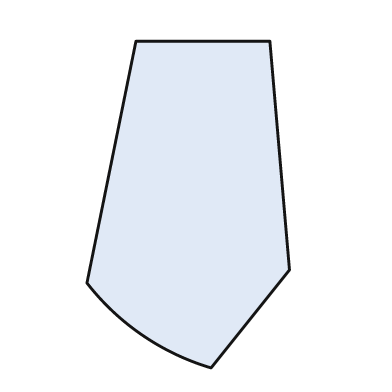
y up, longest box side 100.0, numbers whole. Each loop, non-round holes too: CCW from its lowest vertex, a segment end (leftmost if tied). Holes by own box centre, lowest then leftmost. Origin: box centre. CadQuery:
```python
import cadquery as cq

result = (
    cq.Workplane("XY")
    .moveTo(7.0, -50.0)
    .lineTo(31.0, -20.0)
    .lineTo(25.0, 50.0)
    .lineTo(-16.0, 50.0)
    .lineTo(-31.0, -24.0)
    .threePointArc((-14.0, -40.0), (7.0, -50.0))
    .close()
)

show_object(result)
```